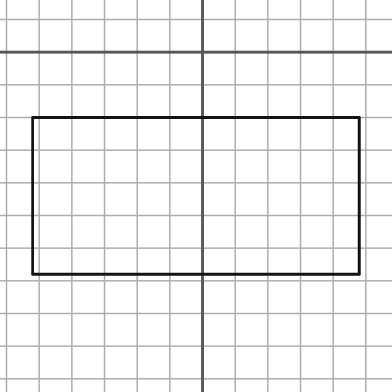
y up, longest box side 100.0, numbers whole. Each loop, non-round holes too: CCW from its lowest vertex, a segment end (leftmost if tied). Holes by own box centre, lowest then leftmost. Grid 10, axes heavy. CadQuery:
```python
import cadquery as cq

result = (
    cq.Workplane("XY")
    .moveTo(-52.0, -68.0)
    .lineTo(48.0, -68.0)
    .lineTo(48.0, -20.0)
    .lineTo(-52.0, -20.0)
    .close()
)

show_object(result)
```